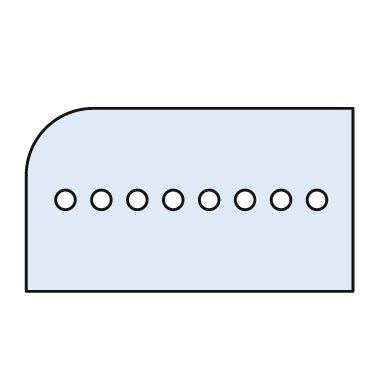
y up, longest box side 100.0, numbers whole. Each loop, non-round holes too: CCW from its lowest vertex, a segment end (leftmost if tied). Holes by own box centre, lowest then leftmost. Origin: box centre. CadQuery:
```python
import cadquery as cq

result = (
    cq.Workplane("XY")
    .moveTo(-50.0, -28.0)
    .lineTo(50.0, -28.0)
    .lineTo(50.0, 28.0)
    .lineTo(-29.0, 28.0)
    .threePointArc((-44.0, 22.0), (-50.0, 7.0))
    .close()
    .moveTo(-38.0, 0.0)
    .circle(3.0)
    .moveTo(-27.0, 0.0)
    .circle(3.0)
    .moveTo(-16.0, 0.0)
    .circle(3.0)
    .moveTo(-5.0, 0.0)
    .circle(3.0)
    .moveTo(6.0, 0.0)
    .circle(3.0)
    .moveTo(17.0, 0.0)
    .circle(3.0)
    .moveTo(28.0, 0.0)
    .circle(3.0)
    .moveTo(39.0, 0.0)
    .circle(3.0)
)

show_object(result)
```